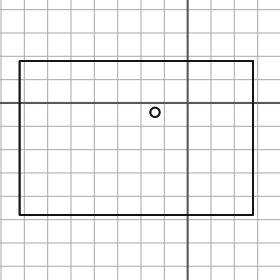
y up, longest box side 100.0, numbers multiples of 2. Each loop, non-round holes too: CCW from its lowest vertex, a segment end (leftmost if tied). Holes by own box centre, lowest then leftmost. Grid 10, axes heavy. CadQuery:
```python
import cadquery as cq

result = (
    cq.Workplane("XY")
    .moveTo(-72.0, -48.0)
    .lineTo(28.0, -48.0)
    .lineTo(28.0, 18.0)
    .lineTo(-72.0, 18.0)
    .close()
    .moveTo(-14.0, -4.0)
    .circle(2.0)
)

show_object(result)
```